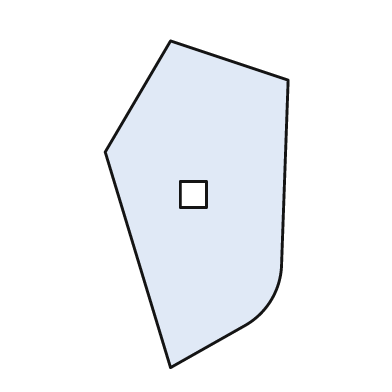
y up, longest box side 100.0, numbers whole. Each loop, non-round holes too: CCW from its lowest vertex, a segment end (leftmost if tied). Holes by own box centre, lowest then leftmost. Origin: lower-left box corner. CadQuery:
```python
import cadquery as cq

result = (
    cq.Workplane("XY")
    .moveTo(20.0, 0.0)
    .lineTo(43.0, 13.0)
    .threePointArc((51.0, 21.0), (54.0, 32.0))
    .lineTo(56.0, 88.0)
    .lineTo(20.0, 100.0)
    .lineTo(0.0, 66.0)
    .close()
    .moveTo(23.0, 49.0)
    .lineTo(31.0, 49.0)
    .lineTo(31.0, 57.0)
    .lineTo(23.0, 57.0)
    .close()
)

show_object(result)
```